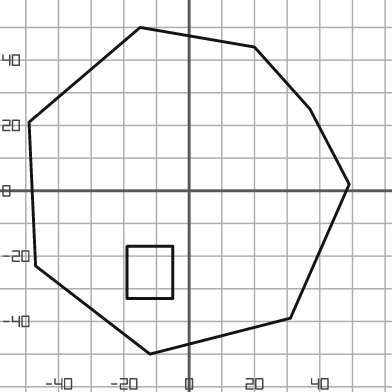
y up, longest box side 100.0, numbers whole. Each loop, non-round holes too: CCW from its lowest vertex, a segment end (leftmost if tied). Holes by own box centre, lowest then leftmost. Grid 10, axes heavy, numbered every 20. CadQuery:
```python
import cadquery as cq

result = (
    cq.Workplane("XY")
    .moveTo(-12.0, -50.0)
    .lineTo(31.0, -39.0)
    .lineTo(49.0, 2.0)
    .lineTo(37.0, 25.0)
    .lineTo(20.0, 44.0)
    .lineTo(-15.0, 50.0)
    .lineTo(-49.0, 21.0)
    .lineTo(-47.0, -23.0)
    .close()
    .moveTo(-19.0, -33.0)
    .lineTo(-5.0, -33.0)
    .lineTo(-5.0, -17.0)
    .lineTo(-19.0, -17.0)
    .close()
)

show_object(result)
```